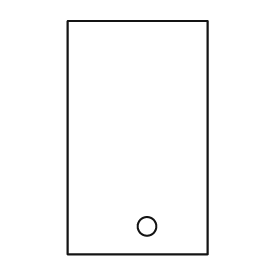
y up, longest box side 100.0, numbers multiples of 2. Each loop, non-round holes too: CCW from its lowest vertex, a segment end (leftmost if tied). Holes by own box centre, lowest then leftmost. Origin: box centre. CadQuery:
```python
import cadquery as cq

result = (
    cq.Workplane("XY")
    .moveTo(-30.0, -50.0)
    .lineTo(30.0, -50.0)
    .lineTo(30.0, 50.0)
    .lineTo(-30.0, 50.0)
    .close()
    .moveTo(4.0, -38.0)
    .circle(4.0)
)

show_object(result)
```